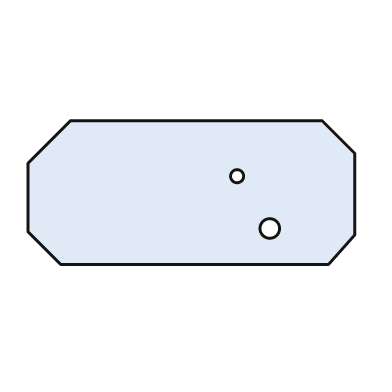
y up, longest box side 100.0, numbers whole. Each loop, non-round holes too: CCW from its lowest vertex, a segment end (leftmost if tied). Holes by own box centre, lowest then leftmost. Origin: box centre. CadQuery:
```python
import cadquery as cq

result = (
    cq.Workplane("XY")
    .moveTo(-40.0, -22.0)
    .lineTo(42.0, -22.0)
    .lineTo(50.0, -13.0)
    .lineTo(50.0, 12.0)
    .lineTo(40.0, 22.0)
    .lineTo(-37.0, 22.0)
    .lineTo(-50.0, 9.0)
    .lineTo(-50.0, -12.0)
    .close()
    .moveTo(24.0, -11.0)
    .circle(3.0)
    .moveTo(14.0, 5.0)
    .circle(2.0)
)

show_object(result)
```